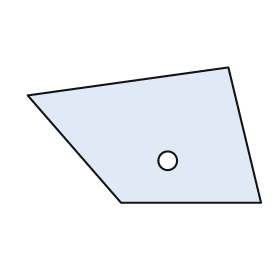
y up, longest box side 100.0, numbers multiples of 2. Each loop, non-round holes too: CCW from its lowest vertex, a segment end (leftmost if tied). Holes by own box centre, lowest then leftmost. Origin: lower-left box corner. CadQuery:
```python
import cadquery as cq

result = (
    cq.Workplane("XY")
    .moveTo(40.0, 0.0)
    .lineTo(100.0, 0.0)
    .lineTo(86.0, 58.0)
    .lineTo(0.0, 46.0)
    .close()
    .moveTo(60.0, 18.0)
    .circle(4.0)
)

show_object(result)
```